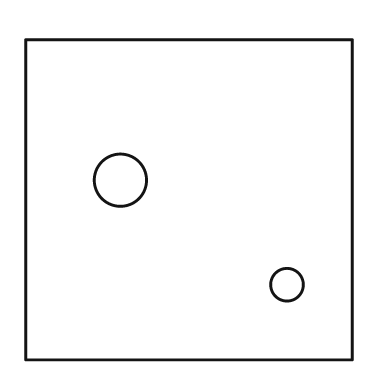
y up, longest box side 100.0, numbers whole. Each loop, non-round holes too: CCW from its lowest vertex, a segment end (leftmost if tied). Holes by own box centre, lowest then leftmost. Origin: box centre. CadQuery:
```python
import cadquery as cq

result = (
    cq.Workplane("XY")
    .moveTo(-50.0, -49.0)
    .lineTo(50.0, -49.0)
    .lineTo(50.0, 49.0)
    .lineTo(-50.0, 49.0)
    .close()
    .moveTo(30.0, -26.0)
    .circle(5.0)
    .moveTo(-21.0, 6.0)
    .circle(8.0)
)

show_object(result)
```